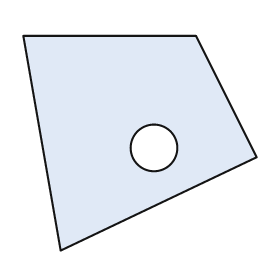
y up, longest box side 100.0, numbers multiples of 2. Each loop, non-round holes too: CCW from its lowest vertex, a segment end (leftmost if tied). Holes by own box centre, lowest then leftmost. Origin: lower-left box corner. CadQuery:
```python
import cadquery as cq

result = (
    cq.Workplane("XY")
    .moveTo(16.0, 0.0)
    .lineTo(100.0, 40.0)
    .lineTo(74.0, 92.0)
    .lineTo(0.0, 92.0)
    .close()
    .moveTo(56.0, 44.0)
    .circle(10.0)
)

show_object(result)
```